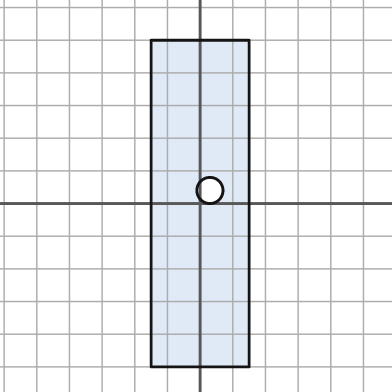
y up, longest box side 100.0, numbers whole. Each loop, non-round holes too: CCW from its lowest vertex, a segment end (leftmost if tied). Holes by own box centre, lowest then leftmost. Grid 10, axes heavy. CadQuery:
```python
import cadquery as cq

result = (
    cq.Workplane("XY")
    .moveTo(-15.0, -50.0)
    .lineTo(15.0, -50.0)
    .lineTo(15.0, 50.0)
    .lineTo(-15.0, 50.0)
    .close()
    .moveTo(3.0, 4.0)
    .circle(4.0)
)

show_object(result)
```